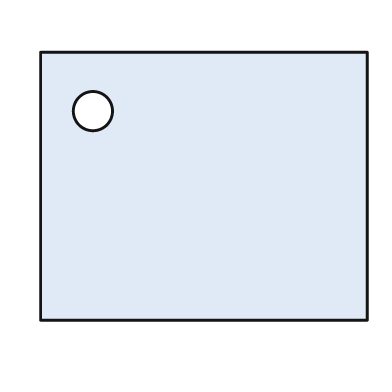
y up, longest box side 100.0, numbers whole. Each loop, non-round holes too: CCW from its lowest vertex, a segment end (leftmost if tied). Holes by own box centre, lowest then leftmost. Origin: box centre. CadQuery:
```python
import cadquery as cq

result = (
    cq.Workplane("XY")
    .moveTo(-50.0, -41.0)
    .lineTo(50.0, -41.0)
    .lineTo(50.0, 41.0)
    .lineTo(-50.0, 41.0)
    .close()
    .moveTo(-34.0, 23.0)
    .circle(6.0)
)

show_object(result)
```